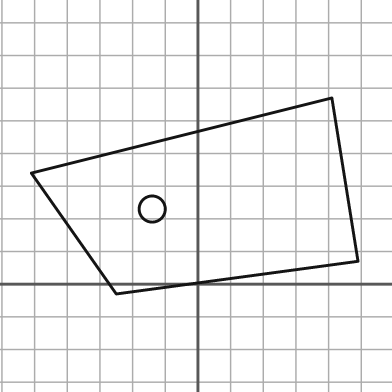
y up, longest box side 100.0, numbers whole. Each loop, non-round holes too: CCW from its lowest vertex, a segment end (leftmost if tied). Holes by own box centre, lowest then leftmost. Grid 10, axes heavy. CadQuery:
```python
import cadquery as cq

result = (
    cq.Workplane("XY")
    .moveTo(-25.0, -3.0)
    .lineTo(49.0, 7.0)
    .lineTo(41.0, 57.0)
    .lineTo(-51.0, 34.0)
    .close()
    .moveTo(-14.0, 23.0)
    .circle(4.0)
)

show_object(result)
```